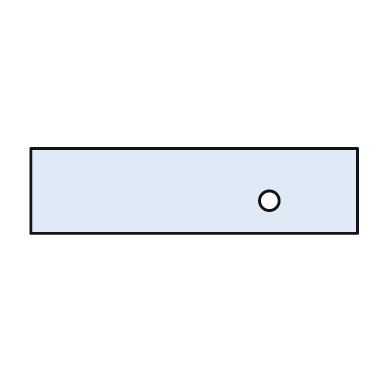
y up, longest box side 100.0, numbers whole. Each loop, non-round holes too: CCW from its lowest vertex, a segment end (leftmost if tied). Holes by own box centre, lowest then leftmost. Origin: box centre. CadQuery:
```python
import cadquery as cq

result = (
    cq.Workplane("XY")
    .moveTo(-50.0, -13.0)
    .lineTo(50.0, -13.0)
    .lineTo(50.0, 13.0)
    .lineTo(-50.0, 13.0)
    .close()
    .moveTo(23.0, -3.0)
    .circle(3.0)
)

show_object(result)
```